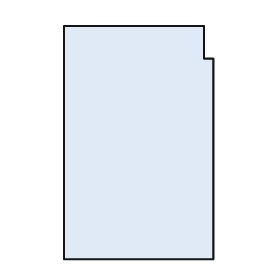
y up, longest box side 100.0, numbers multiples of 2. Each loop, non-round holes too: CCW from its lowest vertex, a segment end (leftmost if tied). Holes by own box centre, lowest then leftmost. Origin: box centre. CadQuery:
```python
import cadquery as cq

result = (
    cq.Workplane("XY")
    .moveTo(-32.0, -50.0)
    .lineTo(32.0, -50.0)
    .lineTo(32.0, 36.0)
    .lineTo(28.0, 36.0)
    .lineTo(28.0, 50.0)
    .lineTo(-32.0, 50.0)
    .close()
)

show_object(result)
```